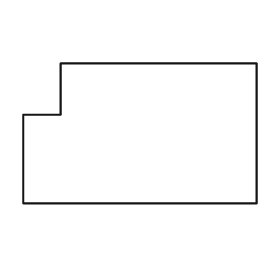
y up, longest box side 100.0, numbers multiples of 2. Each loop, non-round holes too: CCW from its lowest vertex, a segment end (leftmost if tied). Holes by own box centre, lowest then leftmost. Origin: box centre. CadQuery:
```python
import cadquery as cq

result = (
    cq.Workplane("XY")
    .moveTo(-50.0, -30.0)
    .lineTo(50.0, -30.0)
    .lineTo(50.0, 30.0)
    .lineTo(-34.0, 30.0)
    .lineTo(-34.0, 8.0)
    .lineTo(-50.0, 8.0)
    .close()
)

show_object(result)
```